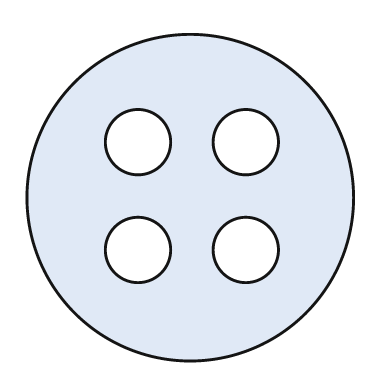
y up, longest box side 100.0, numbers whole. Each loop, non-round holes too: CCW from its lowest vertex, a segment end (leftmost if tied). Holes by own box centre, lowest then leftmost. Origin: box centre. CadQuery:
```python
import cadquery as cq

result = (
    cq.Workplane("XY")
    .moveTo(0.0, 0.0)
    .circle(50.0)
    .moveTo(-16.0, -16.0)
    .circle(10.0)
    .moveTo(17.0, -16.0)
    .circle(10.0)
    .moveTo(-16.0, 17.0)
    .circle(10.0)
    .moveTo(17.0, 17.0)
    .circle(10.0)
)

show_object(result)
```